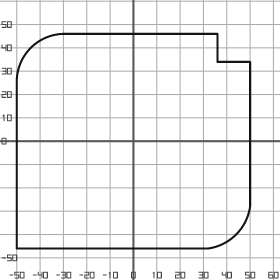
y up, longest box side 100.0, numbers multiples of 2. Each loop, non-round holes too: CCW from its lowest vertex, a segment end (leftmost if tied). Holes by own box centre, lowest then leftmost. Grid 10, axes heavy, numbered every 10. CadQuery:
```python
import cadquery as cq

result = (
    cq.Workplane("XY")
    .moveTo(-50.0, -46.0)
    .lineTo(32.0, -46.0)
    .threePointArc((44.0, -40.0), (50.0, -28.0))
    .lineTo(50.0, 34.0)
    .lineTo(36.0, 34.0)
    .lineTo(36.0, 46.0)
    .lineTo(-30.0, 46.0)
    .threePointArc((-44.0, 40.0), (-50.0, 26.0))
    .close()
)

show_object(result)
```